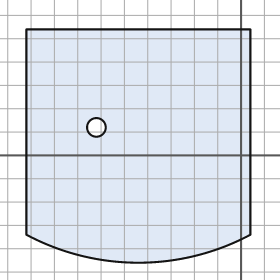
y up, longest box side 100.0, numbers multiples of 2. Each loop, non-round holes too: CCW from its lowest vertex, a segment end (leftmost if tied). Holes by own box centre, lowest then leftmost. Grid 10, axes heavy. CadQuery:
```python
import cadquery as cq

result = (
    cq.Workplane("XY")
    .moveTo(-92.0, -34.0)
    .threePointArc((-44.0, -46.0), (4.0, -34.0))
    .lineTo(4.0, 54.0)
    .lineTo(-92.0, 54.0)
    .close()
    .moveTo(-62.0, 12.0)
    .circle(4.0)
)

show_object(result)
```